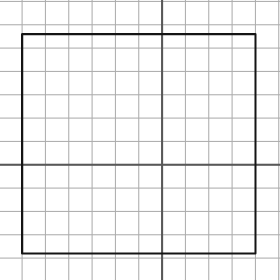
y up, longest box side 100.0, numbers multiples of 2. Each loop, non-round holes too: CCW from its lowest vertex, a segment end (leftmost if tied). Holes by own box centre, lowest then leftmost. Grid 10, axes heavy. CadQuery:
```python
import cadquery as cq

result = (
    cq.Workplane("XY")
    .moveTo(-60.0, -38.0)
    .lineTo(40.0, -38.0)
    .lineTo(40.0, 56.0)
    .lineTo(-60.0, 56.0)
    .close()
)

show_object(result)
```